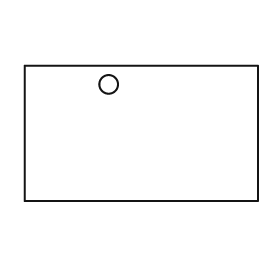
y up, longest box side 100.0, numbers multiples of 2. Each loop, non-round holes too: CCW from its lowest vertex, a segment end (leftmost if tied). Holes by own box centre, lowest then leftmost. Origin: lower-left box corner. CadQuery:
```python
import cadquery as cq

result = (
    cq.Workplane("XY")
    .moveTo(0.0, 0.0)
    .lineTo(100.0, 0.0)
    .lineTo(100.0, 58.0)
    .lineTo(0.0, 58.0)
    .close()
    .moveTo(36.0, 50.0)
    .circle(4.0)
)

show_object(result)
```